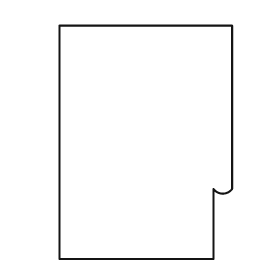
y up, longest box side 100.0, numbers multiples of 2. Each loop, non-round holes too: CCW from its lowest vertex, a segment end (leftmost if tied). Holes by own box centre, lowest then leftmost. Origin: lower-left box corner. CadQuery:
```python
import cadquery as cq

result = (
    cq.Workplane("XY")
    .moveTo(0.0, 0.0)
    .lineTo(66.0, 0.0)
    .lineTo(66.0, 30.0)
    .threePointArc((70.0, 28.0), (74.0, 30.0))
    .lineTo(74.0, 100.0)
    .lineTo(0.0, 100.0)
    .close()
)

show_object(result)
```